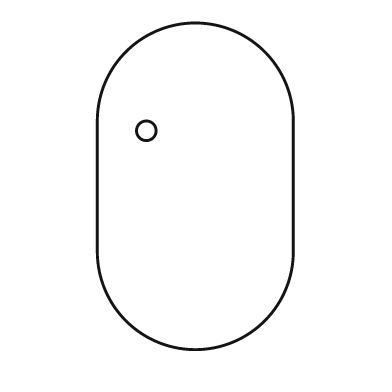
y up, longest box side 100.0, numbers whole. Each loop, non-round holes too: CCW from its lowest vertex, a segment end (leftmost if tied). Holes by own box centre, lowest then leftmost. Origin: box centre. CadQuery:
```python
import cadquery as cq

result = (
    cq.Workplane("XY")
    .moveTo(-30.0, -20.0)
    .threePointArc((0.0, -50.0), (30.0, -20.0))
    .lineTo(30.0, 20.0)
    .threePointArc((0.0, 50.0), (-30.0, 20.0))
    .close()
    .moveTo(-15.0, 17.0)
    .circle(3.0)
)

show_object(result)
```